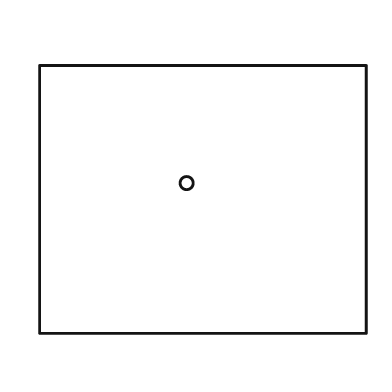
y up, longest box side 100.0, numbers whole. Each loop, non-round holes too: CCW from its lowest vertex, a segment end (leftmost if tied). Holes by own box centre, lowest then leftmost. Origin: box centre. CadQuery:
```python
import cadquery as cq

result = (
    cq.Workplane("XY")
    .moveTo(-50.0, -41.0)
    .lineTo(50.0, -41.0)
    .lineTo(50.0, 41.0)
    .lineTo(-50.0, 41.0)
    .close()
    .moveTo(-5.0, 5.0)
    .circle(2.0)
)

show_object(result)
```